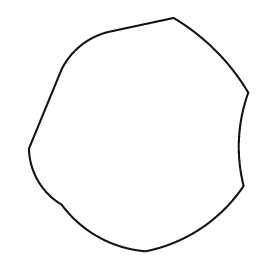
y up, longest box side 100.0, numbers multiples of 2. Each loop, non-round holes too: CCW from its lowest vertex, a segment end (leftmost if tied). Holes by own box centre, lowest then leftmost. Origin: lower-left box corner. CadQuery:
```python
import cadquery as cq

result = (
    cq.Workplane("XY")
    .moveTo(50.0, 0.0)
    .threePointArc((74.0, 10.0), (92.0, 28.0))
    .threePointArc((90.0, 48.0), (94.0, 68.0))
    .threePointArc((80.0, 86.0), (62.0, 100.0))
    .lineTo(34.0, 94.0)
    .threePointArc((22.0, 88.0), (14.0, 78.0))
    .lineTo(0.0, 44.0)
    .threePointArc((4.0, 30.0), (14.0, 20.0))
    .threePointArc((30.0, 6.0), (50.0, 0.0))
    .close()
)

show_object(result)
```